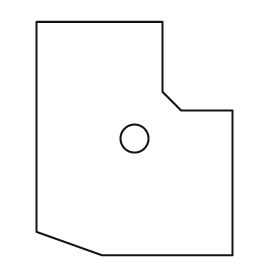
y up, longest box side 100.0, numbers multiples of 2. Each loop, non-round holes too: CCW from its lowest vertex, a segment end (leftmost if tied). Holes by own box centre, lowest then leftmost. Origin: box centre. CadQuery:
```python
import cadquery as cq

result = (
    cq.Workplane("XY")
    .moveTo(-14.0, -50.0)
    .lineTo(42.0, -50.0)
    .lineTo(42.0, 12.0)
    .lineTo(20.0, 12.0)
    .lineTo(12.0, 20.0)
    .lineTo(12.0, 50.0)
    .lineTo(-42.0, 50.0)
    .lineTo(-42.0, -40.0)
    .close()
    .moveTo(0.0, 0.0)
    .circle(6.0)
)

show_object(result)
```